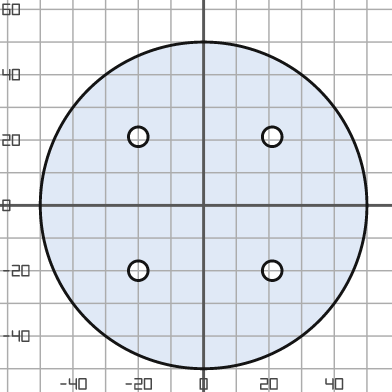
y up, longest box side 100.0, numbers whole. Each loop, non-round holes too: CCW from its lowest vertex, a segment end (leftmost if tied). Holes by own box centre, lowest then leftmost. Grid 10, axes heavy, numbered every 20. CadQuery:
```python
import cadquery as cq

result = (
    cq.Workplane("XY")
    .moveTo(0.0, 0.0)
    .circle(50.0)
    .moveTo(-20.0, -20.0)
    .circle(3.0)
    .moveTo(21.0, -20.0)
    .circle(3.0)
    .moveTo(-20.0, 21.0)
    .circle(3.0)
    .moveTo(21.0, 21.0)
    .circle(3.0)
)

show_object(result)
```